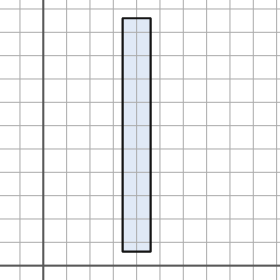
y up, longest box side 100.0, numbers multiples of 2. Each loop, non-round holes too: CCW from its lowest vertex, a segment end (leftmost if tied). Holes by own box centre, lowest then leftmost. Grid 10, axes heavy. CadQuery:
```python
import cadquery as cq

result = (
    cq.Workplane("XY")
    .moveTo(34.0, 6.0)
    .lineTo(46.0, 6.0)
    .lineTo(46.0, 106.0)
    .lineTo(34.0, 106.0)
    .close()
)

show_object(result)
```